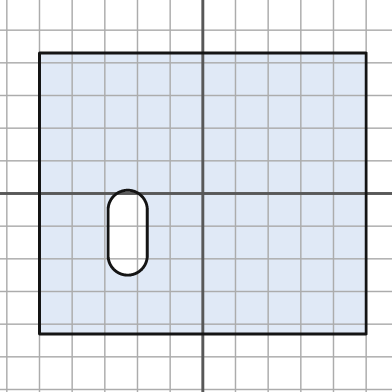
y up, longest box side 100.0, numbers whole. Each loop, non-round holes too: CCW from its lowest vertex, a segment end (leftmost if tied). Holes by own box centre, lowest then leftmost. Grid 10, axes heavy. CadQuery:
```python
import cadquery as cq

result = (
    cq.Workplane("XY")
    .moveTo(-50.0, -43.0)
    .lineTo(50.0, -43.0)
    .lineTo(50.0, 43.0)
    .lineTo(-50.0, 43.0)
    .close()
    .moveTo(-29.0, -19.0)
    .threePointArc((-23.0, -25.0), (-17.0, -19.0))
    .lineTo(-17.0, -5.0)
    .threePointArc((-23.0, 1.0), (-29.0, -5.0))
    .close()
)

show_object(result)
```